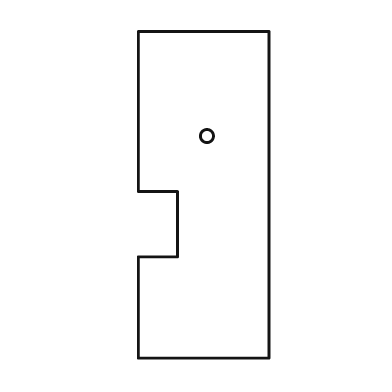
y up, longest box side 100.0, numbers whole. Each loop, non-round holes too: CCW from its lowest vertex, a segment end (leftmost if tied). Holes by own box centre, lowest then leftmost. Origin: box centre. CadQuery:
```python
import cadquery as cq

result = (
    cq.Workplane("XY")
    .moveTo(-20.0, -50.0)
    .lineTo(20.0, -50.0)
    .lineTo(20.0, 50.0)
    .lineTo(-20.0, 50.0)
    .lineTo(-20.0, 1.0)
    .lineTo(-8.0, 1.0)
    .lineTo(-8.0, -19.0)
    .lineTo(-20.0, -19.0)
    .close()
    .moveTo(1.0, 18.0)
    .circle(2.0)
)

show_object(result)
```